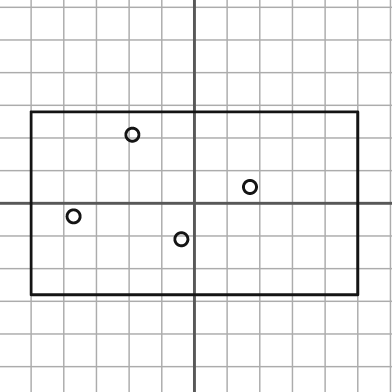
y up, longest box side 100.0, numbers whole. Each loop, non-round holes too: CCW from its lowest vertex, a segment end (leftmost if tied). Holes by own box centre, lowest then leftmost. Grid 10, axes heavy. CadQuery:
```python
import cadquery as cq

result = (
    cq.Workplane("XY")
    .moveTo(-50.0, -28.0)
    .lineTo(50.0, -28.0)
    .lineTo(50.0, 28.0)
    .lineTo(-50.0, 28.0)
    .close()
    .moveTo(-4.0, -11.0)
    .circle(2.0)
    .moveTo(-37.0, -4.0)
    .circle(2.0)
    .moveTo(17.0, 5.0)
    .circle(2.0)
    .moveTo(-19.0, 21.0)
    .circle(2.0)
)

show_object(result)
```